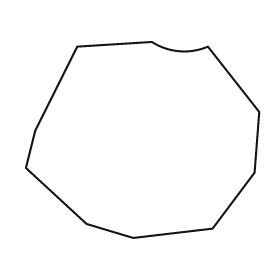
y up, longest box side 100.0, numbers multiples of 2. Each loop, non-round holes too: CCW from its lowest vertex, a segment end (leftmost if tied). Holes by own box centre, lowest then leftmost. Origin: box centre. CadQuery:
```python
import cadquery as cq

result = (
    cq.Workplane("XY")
    .moveTo(-4.0, -42.0)
    .lineTo(30.0, -38.0)
    .lineTo(48.0, -14.0)
    .lineTo(50.0, 12.0)
    .lineTo(28.0, 40.0)
    .threePointArc((16.0, 38.0), (4.0, 42.0))
    .lineTo(-28.0, 40.0)
    .lineTo(-46.0, 4.0)
    .lineTo(-50.0, -12.0)
    .lineTo(-24.0, -36.0)
    .close()
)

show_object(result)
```